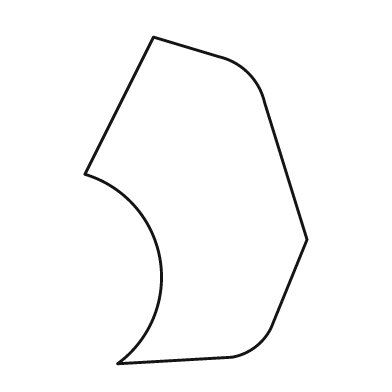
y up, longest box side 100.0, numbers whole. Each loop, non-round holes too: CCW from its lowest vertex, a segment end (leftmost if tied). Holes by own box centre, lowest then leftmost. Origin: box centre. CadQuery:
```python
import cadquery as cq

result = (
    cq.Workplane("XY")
    .moveTo(-24.0, -50.0)
    .lineTo(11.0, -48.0)
    .threePointArc((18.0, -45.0), (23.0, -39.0))
    .lineTo(34.0, -12.0)
    .lineTo(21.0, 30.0)
    .threePointArc((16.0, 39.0), (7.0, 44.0))
    .lineTo(-13.0, 50.0)
    .lineTo(-34.0, 8.0)
    .threePointArc((-11.0, -18.0), (-24.0, -50.0))
    .close()
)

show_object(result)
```